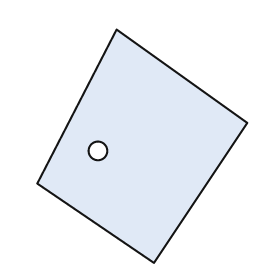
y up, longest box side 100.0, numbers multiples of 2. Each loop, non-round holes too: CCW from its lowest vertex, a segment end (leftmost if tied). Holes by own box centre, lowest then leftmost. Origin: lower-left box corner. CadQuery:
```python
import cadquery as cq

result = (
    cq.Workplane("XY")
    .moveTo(50.0, 0.0)
    .lineTo(90.0, 60.0)
    .lineTo(34.0, 100.0)
    .lineTo(0.0, 34.0)
    .close()
    .moveTo(26.0, 48.0)
    .circle(4.0)
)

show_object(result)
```